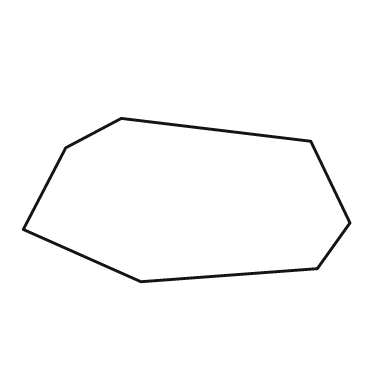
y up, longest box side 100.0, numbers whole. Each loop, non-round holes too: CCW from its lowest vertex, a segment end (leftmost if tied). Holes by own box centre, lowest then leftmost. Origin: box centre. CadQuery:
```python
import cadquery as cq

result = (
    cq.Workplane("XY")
    .moveTo(-14.0, -25.0)
    .lineTo(40.0, -21.0)
    .lineTo(50.0, -7.0)
    .lineTo(38.0, 18.0)
    .lineTo(-20.0, 25.0)
    .lineTo(-37.0, 16.0)
    .lineTo(-50.0, -9.0)
    .close()
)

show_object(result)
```